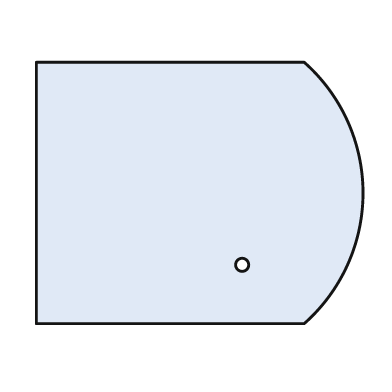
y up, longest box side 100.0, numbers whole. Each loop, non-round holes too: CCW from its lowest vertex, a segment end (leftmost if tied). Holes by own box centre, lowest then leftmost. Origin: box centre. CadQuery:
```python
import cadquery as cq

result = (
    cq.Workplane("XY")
    .moveTo(-50.0, -40.0)
    .lineTo(32.0, -40.0)
    .threePointArc((50.0, 0.0), (32.0, 40.0))
    .lineTo(-50.0, 40.0)
    .close()
    .moveTo(13.0, -22.0)
    .circle(2.0)
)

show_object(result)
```